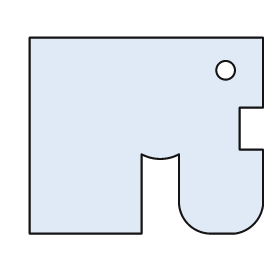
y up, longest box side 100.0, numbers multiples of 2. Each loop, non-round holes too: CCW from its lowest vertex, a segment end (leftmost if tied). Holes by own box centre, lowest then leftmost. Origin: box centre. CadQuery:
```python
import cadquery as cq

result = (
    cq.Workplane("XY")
    .moveTo(-50.0, -42.0)
    .lineTo(-2.0, -42.0)
    .lineTo(-2.0, -8.0)
    .threePointArc((6.0, -10.0), (14.0, -8.0))
    .lineTo(14.0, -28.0)
    .threePointArc((18.0, -38.0), (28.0, -42.0))
    .lineTo(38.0, -42.0)
    .threePointArc((46.0, -38.0), (50.0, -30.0))
    .lineTo(50.0, -6.0)
    .lineTo(40.0, -6.0)
    .lineTo(40.0, 12.0)
    .lineTo(50.0, 12.0)
    .lineTo(50.0, 42.0)
    .lineTo(-50.0, 42.0)
    .close()
    .moveTo(34.0, 28.0)
    .circle(4.0)
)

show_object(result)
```